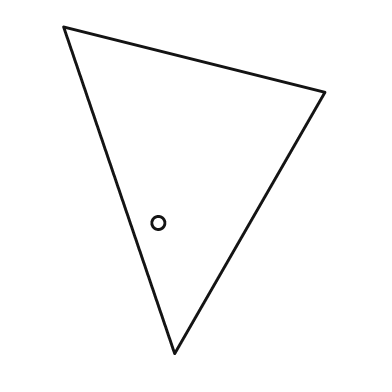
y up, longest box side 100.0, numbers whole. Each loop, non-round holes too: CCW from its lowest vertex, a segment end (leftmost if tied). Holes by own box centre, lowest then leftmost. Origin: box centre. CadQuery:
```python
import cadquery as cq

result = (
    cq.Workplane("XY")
    .moveTo(-6.0, -50.0)
    .lineTo(40.0, 30.0)
    .lineTo(-40.0, 50.0)
    .close()
    .moveTo(-11.0, -10.0)
    .circle(2.0)
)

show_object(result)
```